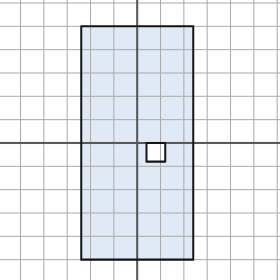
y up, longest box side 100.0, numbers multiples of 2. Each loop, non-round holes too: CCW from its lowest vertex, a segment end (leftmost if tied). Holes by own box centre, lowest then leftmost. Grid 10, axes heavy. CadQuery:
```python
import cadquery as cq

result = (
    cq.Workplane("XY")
    .moveTo(-24.0, -50.0)
    .lineTo(24.0, -50.0)
    .lineTo(24.0, 50.0)
    .lineTo(-24.0, 50.0)
    .close()
    .moveTo(4.0, -8.0)
    .lineTo(12.0, -8.0)
    .lineTo(12.0, 0.0)
    .lineTo(4.0, 0.0)
    .close()
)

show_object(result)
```